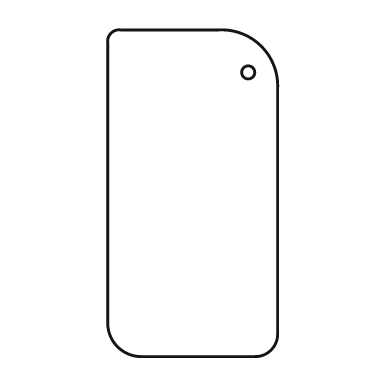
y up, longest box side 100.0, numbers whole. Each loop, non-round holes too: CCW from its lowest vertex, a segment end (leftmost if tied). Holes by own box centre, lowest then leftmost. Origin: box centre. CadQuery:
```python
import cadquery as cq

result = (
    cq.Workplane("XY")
    .moveTo(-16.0, -50.0)
    .lineTo(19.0, -50.0)
    .threePointArc((24.0, -48.0), (26.0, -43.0))
    .lineTo(26.0, 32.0)
    .threePointArc((21.0, 45.0), (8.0, 50.0))
    .lineTo(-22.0, 50.0)
    .threePointArc((-25.0, 49.0), (-26.0, 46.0))
    .lineTo(-26.0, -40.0)
    .threePointArc((-23.0, -47.0), (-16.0, -50.0))
    .close()
    .moveTo(17.0, 37.0)
    .circle(2.0)
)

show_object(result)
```